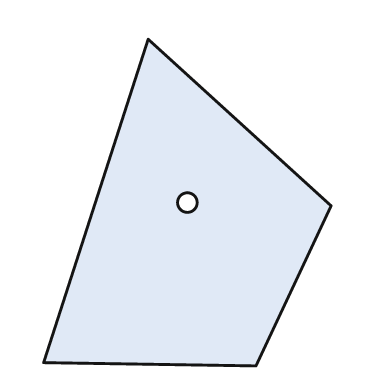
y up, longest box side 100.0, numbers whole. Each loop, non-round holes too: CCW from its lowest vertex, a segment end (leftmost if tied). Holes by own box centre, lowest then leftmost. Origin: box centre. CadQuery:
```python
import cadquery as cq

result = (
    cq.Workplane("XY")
    .moveTo(21.0, -50.0)
    .lineTo(44.0, -1.0)
    .lineTo(-12.0, 50.0)
    .lineTo(-44.0, -49.0)
    .close()
    .moveTo(0.0, 0.0)
    .circle(3.0)
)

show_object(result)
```